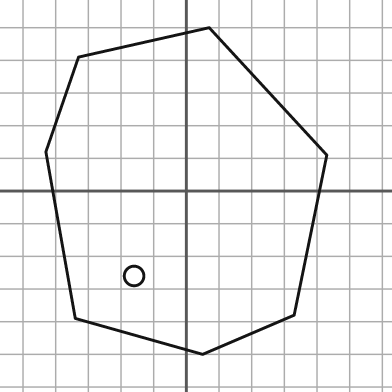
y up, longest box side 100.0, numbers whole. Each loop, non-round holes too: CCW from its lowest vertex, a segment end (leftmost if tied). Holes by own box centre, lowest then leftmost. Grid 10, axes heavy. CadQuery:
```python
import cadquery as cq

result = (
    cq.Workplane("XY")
    .moveTo(5.0, -50.0)
    .lineTo(33.0, -38.0)
    .lineTo(43.0, 11.0)
    .lineTo(7.0, 50.0)
    .lineTo(-33.0, 41.0)
    .lineTo(-43.0, 12.0)
    .lineTo(-34.0, -39.0)
    .close()
    .moveTo(-16.0, -26.0)
    .circle(3.0)
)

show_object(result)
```